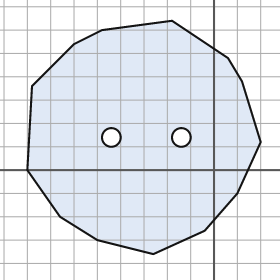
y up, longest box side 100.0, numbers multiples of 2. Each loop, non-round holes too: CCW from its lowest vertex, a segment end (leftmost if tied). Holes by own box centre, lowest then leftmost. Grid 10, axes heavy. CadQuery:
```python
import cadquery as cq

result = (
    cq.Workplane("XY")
    .moveTo(-26.0, -36.0)
    .lineTo(-4.0, -26.0)
    .lineTo(10.0, -10.0)
    .lineTo(20.0, 12.0)
    .lineTo(12.0, 38.0)
    .lineTo(6.0, 48.0)
    .lineTo(-18.0, 64.0)
    .lineTo(-48.0, 60.0)
    .lineTo(-60.0, 54.0)
    .lineTo(-78.0, 36.0)
    .lineTo(-80.0, 0.0)
    .lineTo(-66.0, -20.0)
    .lineTo(-50.0, -30.0)
    .close()
    .moveTo(-44.0, 14.0)
    .circle(4.0)
    .moveTo(-14.0, 14.0)
    .circle(4.0)
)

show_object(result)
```